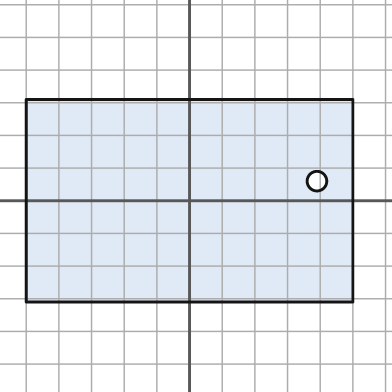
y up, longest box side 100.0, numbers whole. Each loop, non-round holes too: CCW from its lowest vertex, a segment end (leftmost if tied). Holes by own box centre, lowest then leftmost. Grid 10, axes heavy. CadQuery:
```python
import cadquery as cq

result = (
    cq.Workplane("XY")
    .moveTo(-50.0, -31.0)
    .lineTo(50.0, -31.0)
    .lineTo(50.0, 31.0)
    .lineTo(-50.0, 31.0)
    .close()
    .moveTo(39.0, 6.0)
    .circle(3.0)
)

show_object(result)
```